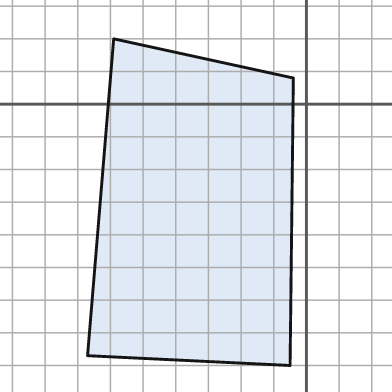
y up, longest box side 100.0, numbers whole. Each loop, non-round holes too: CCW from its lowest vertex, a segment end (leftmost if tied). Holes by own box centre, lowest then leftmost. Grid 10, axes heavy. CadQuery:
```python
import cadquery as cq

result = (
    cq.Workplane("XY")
    .moveTo(-5.0, -80.0)
    .lineTo(-4.0, 8.0)
    .lineTo(-59.0, 20.0)
    .lineTo(-67.0, -77.0)
    .close()
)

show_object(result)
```